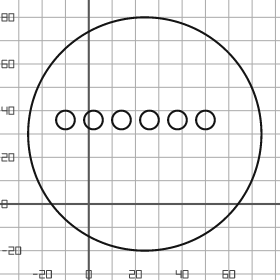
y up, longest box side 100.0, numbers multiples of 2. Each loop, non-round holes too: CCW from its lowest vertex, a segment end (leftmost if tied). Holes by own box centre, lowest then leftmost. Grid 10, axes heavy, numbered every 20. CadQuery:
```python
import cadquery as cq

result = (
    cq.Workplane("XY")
    .moveTo(24.0, 30.0)
    .circle(50.0)
    .moveTo(-10.0, 36.0)
    .circle(4.0)
    .moveTo(2.0, 36.0)
    .circle(4.0)
    .moveTo(14.0, 36.0)
    .circle(4.0)
    .moveTo(26.0, 36.0)
    .circle(4.0)
    .moveTo(38.0, 36.0)
    .circle(4.0)
    .moveTo(50.0, 36.0)
    .circle(4.0)
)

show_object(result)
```